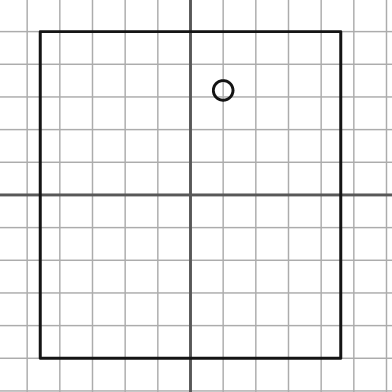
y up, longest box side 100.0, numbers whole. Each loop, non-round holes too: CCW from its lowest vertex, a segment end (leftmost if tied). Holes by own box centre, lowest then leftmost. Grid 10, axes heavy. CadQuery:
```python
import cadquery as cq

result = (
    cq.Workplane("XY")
    .moveTo(-46.0, -50.0)
    .lineTo(46.0, -50.0)
    .lineTo(46.0, 50.0)
    .lineTo(-46.0, 50.0)
    .close()
    .moveTo(10.0, 32.0)
    .circle(3.0)
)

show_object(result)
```